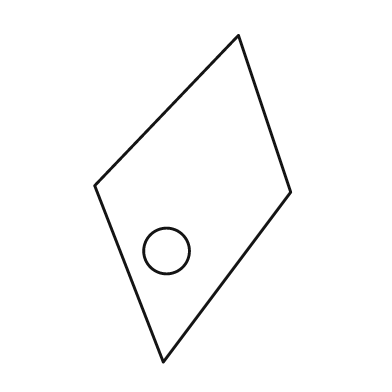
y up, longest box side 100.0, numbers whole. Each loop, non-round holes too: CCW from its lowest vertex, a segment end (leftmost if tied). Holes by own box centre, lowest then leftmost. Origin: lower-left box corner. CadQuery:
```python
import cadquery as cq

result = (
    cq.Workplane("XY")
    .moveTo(21.0, 0.0)
    .lineTo(60.0, 52.0)
    .lineTo(44.0, 100.0)
    .lineTo(0.0, 54.0)
    .close()
    .moveTo(22.0, 34.0)
    .circle(7.0)
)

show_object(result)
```